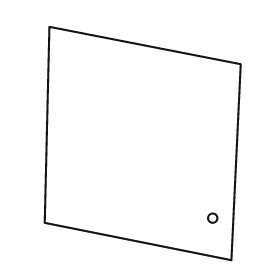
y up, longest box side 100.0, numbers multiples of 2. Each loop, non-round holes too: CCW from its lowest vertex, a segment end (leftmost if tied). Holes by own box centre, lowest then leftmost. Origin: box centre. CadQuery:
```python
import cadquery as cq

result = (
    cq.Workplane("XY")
    .moveTo(38.0, -50.0)
    .lineTo(42.0, 34.0)
    .lineTo(-40.0, 50.0)
    .lineTo(-42.0, -34.0)
    .close()
    .moveTo(30.0, -32.0)
    .circle(2.0)
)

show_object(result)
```